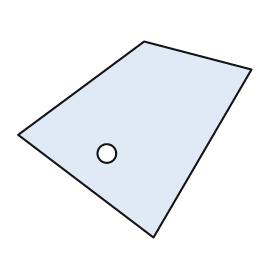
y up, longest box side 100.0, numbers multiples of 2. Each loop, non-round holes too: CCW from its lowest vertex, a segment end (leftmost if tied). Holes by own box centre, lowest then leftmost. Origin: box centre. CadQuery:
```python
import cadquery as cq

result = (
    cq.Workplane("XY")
    .moveTo(8.0, -42.0)
    .lineTo(50.0, 30.0)
    .lineTo(4.0, 42.0)
    .lineTo(-50.0, 2.0)
    .close()
    .moveTo(-12.0, -6.0)
    .circle(4.0)
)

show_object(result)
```